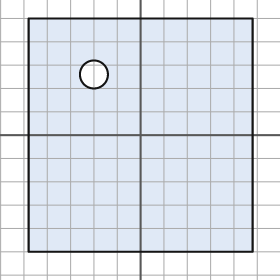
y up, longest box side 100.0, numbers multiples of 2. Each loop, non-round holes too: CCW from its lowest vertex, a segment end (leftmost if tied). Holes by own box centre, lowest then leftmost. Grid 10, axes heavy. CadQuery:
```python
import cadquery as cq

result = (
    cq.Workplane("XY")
    .moveTo(-48.0, -50.0)
    .lineTo(48.0, -50.0)
    .lineTo(48.0, 50.0)
    .lineTo(-48.0, 50.0)
    .close()
    .moveTo(-20.0, 26.0)
    .circle(6.0)
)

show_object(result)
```